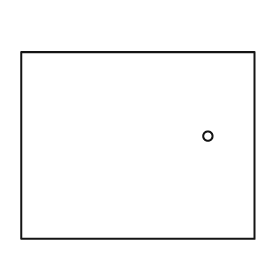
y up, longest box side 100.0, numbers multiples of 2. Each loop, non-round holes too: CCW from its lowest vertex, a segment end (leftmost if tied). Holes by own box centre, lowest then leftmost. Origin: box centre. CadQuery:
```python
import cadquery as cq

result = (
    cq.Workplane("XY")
    .moveTo(-50.0, -40.0)
    .lineTo(50.0, -40.0)
    .lineTo(50.0, 40.0)
    .lineTo(-50.0, 40.0)
    .close()
    .moveTo(30.0, 4.0)
    .circle(2.0)
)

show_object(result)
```